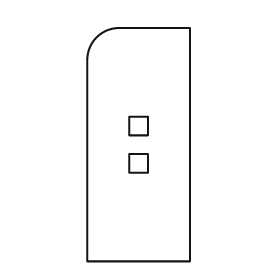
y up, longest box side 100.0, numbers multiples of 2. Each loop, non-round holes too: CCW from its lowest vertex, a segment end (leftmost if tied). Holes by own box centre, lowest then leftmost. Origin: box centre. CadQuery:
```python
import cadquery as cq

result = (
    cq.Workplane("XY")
    .moveTo(-22.0, -50.0)
    .lineTo(22.0, -50.0)
    .lineTo(22.0, 50.0)
    .lineTo(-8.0, 50.0)
    .threePointArc((-18.0, 46.0), (-22.0, 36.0))
    .close()
    .moveTo(-4.0, -12.0)
    .lineTo(4.0, -12.0)
    .lineTo(4.0, -4.0)
    .lineTo(-4.0, -4.0)
    .close()
    .moveTo(-4.0, 4.0)
    .lineTo(4.0, 4.0)
    .lineTo(4.0, 12.0)
    .lineTo(-4.0, 12.0)
    .close()
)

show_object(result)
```